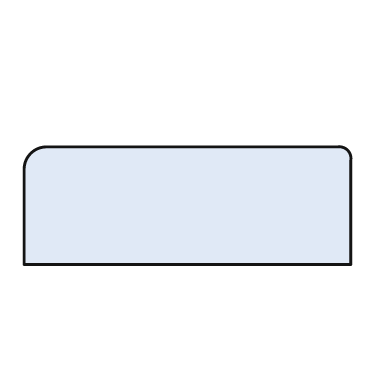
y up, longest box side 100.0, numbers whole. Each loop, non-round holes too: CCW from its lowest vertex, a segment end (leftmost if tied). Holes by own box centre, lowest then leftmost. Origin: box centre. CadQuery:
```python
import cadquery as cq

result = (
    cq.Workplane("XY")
    .moveTo(-50.0, -18.0)
    .lineTo(50.0, -18.0)
    .lineTo(50.0, 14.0)
    .threePointArc((49.0, 17.0), (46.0, 18.0))
    .lineTo(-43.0, 18.0)
    .threePointArc((-48.0, 16.0), (-50.0, 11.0))
    .close()
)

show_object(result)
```